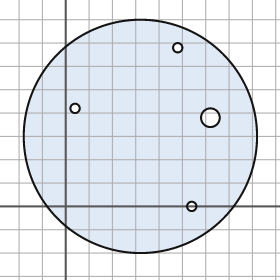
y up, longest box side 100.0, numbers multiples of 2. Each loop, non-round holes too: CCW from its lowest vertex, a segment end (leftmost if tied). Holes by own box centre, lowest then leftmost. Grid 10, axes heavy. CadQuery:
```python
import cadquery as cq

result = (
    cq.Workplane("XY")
    .moveTo(32.0, 30.0)
    .circle(50.0)
    .moveTo(54.0, 0.0)
    .circle(2.0)
    .moveTo(62.0, 38.0)
    .circle(4.0)
    .moveTo(4.0, 42.0)
    .circle(2.0)
    .moveTo(48.0, 68.0)
    .circle(2.0)
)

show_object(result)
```